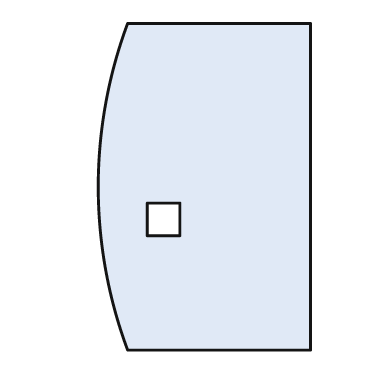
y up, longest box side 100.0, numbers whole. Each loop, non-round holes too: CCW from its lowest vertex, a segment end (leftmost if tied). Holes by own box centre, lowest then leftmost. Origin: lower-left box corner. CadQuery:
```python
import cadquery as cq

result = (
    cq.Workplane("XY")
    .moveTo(9.0, 0.0)
    .lineTo(65.0, 0.0)
    .lineTo(65.0, 100.0)
    .lineTo(9.0, 100.0)
    .threePointArc((0.0, 50.0), (9.0, 0.0))
    .close()
    .moveTo(15.0, 35.0)
    .lineTo(25.0, 35.0)
    .lineTo(25.0, 45.0)
    .lineTo(15.0, 45.0)
    .close()
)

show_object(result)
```